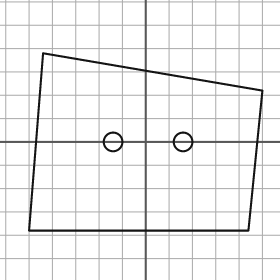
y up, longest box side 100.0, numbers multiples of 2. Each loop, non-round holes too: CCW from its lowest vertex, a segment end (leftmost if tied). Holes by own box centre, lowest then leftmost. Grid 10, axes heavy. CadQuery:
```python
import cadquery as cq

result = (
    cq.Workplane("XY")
    .moveTo(-50.0, -38.0)
    .lineTo(44.0, -38.0)
    .lineTo(50.0, 22.0)
    .lineTo(-44.0, 38.0)
    .close()
    .moveTo(-14.0, 0.0)
    .circle(4.0)
    .moveTo(16.0, 0.0)
    .circle(4.0)
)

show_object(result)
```